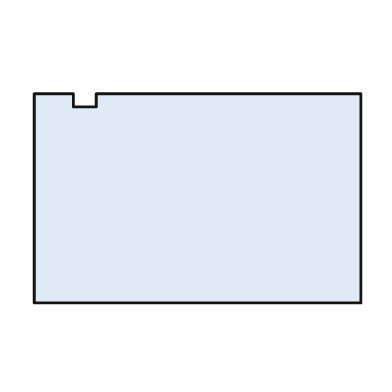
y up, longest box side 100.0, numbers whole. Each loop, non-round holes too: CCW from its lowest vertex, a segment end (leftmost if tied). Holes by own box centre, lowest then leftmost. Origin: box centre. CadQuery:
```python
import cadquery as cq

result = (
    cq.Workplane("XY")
    .moveTo(-50.0, -32.0)
    .lineTo(50.0, -32.0)
    .lineTo(50.0, 32.0)
    .lineTo(-31.0, 32.0)
    .lineTo(-31.0, 28.0)
    .lineTo(-38.0, 28.0)
    .lineTo(-38.0, 32.0)
    .lineTo(-50.0, 32.0)
    .close()
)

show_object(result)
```